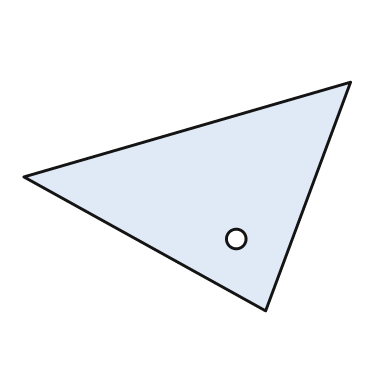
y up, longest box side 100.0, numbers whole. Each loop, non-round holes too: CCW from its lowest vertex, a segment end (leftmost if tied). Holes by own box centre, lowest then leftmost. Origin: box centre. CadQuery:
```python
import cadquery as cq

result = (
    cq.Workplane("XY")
    .moveTo(24.0, -35.0)
    .lineTo(50.0, 35.0)
    .lineTo(-50.0, 6.0)
    .close()
    .moveTo(15.0, -13.0)
    .circle(3.0)
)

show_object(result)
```